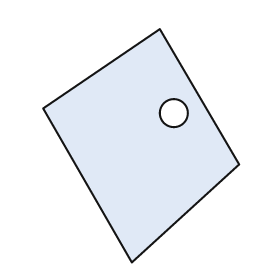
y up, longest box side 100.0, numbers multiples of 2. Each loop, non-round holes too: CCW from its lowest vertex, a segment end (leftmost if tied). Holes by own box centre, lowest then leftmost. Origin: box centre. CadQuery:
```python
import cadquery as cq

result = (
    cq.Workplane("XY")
    .moveTo(-4.0, -50.0)
    .lineTo(42.0, -8.0)
    .lineTo(8.0, 50.0)
    .lineTo(-42.0, 16.0)
    .close()
    .moveTo(14.0, 14.0)
    .circle(6.0)
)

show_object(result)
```